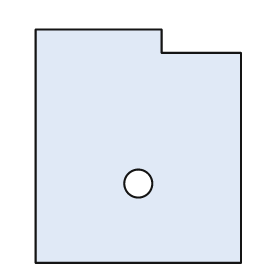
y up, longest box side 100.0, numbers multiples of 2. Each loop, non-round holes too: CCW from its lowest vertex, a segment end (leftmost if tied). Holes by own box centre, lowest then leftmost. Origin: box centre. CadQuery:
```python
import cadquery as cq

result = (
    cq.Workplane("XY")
    .moveTo(-44.0, -50.0)
    .lineTo(44.0, -50.0)
    .lineTo(44.0, 40.0)
    .lineTo(10.0, 40.0)
    .lineTo(10.0, 50.0)
    .lineTo(-44.0, 50.0)
    .close()
    .moveTo(0.0, -16.0)
    .circle(6.0)
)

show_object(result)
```